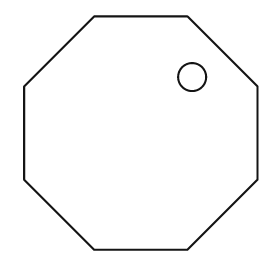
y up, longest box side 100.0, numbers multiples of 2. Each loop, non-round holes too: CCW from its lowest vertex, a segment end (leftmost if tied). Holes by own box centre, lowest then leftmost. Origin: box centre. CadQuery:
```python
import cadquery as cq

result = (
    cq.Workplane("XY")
    .moveTo(-20.0, -50.0)
    .lineTo(20.0, -50.0)
    .lineTo(50.0, -20.0)
    .lineTo(50.0, 20.0)
    .lineTo(20.0, 50.0)
    .lineTo(-20.0, 50.0)
    .lineTo(-50.0, 20.0)
    .lineTo(-50.0, -20.0)
    .close()
    .moveTo(22.0, 24.0)
    .circle(6.0)
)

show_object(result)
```